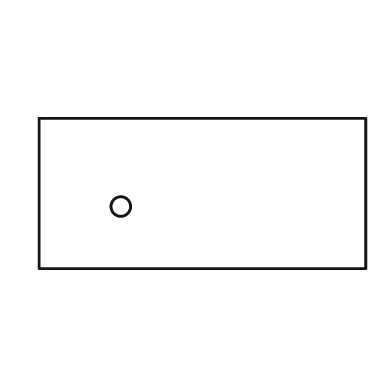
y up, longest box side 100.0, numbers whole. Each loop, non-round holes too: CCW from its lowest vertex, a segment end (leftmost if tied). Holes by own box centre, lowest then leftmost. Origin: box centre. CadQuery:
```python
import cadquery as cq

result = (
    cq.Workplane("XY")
    .moveTo(-50.0, -23.0)
    .lineTo(50.0, -23.0)
    .lineTo(50.0, 23.0)
    .lineTo(-50.0, 23.0)
    .close()
    .moveTo(-25.0, -4.0)
    .circle(3.0)
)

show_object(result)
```